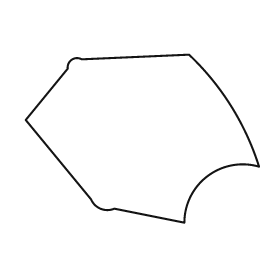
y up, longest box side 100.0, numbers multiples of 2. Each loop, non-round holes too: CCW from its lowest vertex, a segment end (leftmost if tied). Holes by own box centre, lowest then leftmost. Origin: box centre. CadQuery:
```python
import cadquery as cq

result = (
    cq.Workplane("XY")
    .moveTo(18.0, -36.0)
    .threePointArc((28.0, -16.0), (50.0, -12.0))
    .threePointArc((38.0, 14.0), (20.0, 36.0))
    .lineTo(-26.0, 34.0)
    .threePointArc((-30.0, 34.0), (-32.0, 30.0))
    .lineTo(-50.0, 8.0)
    .lineTo(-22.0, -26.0)
    .threePointArc((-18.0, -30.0), (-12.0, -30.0))
    .close()
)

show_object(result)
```